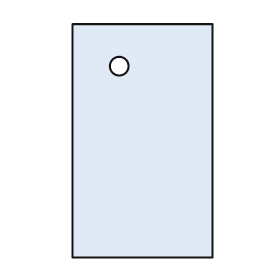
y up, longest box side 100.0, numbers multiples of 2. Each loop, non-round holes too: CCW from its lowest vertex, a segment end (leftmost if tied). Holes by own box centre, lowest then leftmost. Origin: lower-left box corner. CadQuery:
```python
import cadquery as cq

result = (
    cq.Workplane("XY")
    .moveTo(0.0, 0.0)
    .lineTo(60.0, 0.0)
    .lineTo(60.0, 100.0)
    .lineTo(0.0, 100.0)
    .close()
    .moveTo(20.0, 82.0)
    .circle(4.0)
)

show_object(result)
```